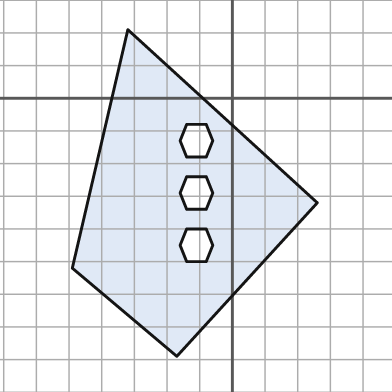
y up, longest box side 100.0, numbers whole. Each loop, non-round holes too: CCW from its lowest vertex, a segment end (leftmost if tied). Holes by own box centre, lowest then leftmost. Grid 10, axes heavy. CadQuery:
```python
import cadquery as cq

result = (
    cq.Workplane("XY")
    .moveTo(-17.0, -79.0)
    .lineTo(26.0, -32.0)
    .lineTo(-32.0, 21.0)
    .lineTo(-49.0, -52.0)
    .close()
    .moveTo(-14.0, -50.0)
    .lineTo(-8.0, -50.0)
    .lineTo(-6.0, -45.0)
    .lineTo(-8.0, -40.0)
    .lineTo(-14.0, -40.0)
    .lineTo(-16.0, -45.0)
    .close()
    .moveTo(-14.0, -34.0)
    .lineTo(-8.0, -34.0)
    .lineTo(-6.0, -29.0)
    .lineTo(-8.0, -24.0)
    .lineTo(-14.0, -24.0)
    .lineTo(-16.0, -29.0)
    .close()
    .moveTo(-14.0, -18.0)
    .lineTo(-8.0, -18.0)
    .lineTo(-6.0, -13.0)
    .lineTo(-8.0, -8.0)
    .lineTo(-14.0, -8.0)
    .lineTo(-16.0, -13.0)
    .close()
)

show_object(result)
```